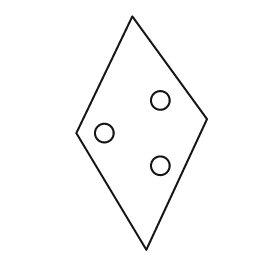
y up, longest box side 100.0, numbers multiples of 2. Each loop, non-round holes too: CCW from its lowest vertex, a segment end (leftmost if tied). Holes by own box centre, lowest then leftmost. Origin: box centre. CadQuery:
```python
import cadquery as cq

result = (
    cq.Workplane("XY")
    .moveTo(2.0, -50.0)
    .lineTo(28.0, 6.0)
    .lineTo(-4.0, 50.0)
    .lineTo(-28.0, 0.0)
    .close()
    .moveTo(8.0, -14.0)
    .circle(4.0)
    .moveTo(-16.0, 0.0)
    .circle(4.0)
    .moveTo(8.0, 14.0)
    .circle(4.0)
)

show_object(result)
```